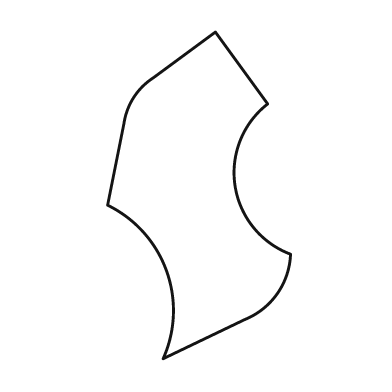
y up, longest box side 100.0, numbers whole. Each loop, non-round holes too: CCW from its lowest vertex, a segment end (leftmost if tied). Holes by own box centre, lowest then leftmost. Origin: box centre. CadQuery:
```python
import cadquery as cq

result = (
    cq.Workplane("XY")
    .moveTo(-11.0, -50.0)
    .lineTo(14.0, -38.0)
    .threePointArc((24.0, -30.0), (28.0, -18.0))
    .threePointArc((11.0, 3.0), (21.0, 28.0))
    .lineTo(5.0, 50.0)
    .lineTo(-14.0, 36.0)
    .threePointArc((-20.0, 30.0), (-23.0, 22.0))
    .lineTo(-28.0, -3.0)
    .threePointArc((-10.0, -23.0), (-11.0, -50.0))
    .close()
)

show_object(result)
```